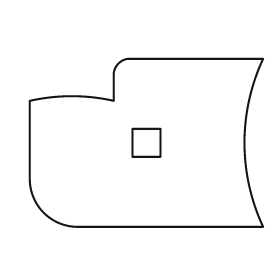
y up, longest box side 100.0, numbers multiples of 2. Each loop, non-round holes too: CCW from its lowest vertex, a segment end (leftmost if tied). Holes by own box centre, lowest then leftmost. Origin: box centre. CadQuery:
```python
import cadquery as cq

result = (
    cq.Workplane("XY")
    .moveTo(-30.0, -36.0)
    .lineTo(50.0, -36.0)
    .threePointArc((42.0, 0.0), (50.0, 36.0))
    .lineTo(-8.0, 36.0)
    .threePointArc((-12.0, 34.0), (-14.0, 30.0))
    .lineTo(-14.0, 18.0)
    .threePointArc((-32.0, 20.0), (-50.0, 18.0))
    .lineTo(-50.0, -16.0)
    .threePointArc((-44.0, -30.0), (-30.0, -36.0))
    .close()
    .moveTo(-6.0, -6.0)
    .lineTo(6.0, -6.0)
    .lineTo(6.0, 6.0)
    .lineTo(-6.0, 6.0)
    .close()
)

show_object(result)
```